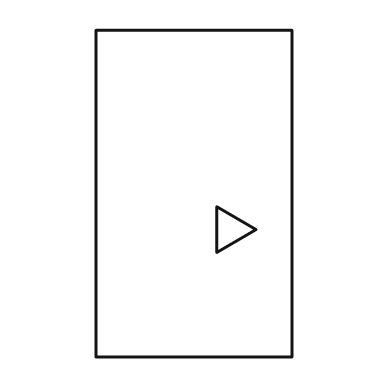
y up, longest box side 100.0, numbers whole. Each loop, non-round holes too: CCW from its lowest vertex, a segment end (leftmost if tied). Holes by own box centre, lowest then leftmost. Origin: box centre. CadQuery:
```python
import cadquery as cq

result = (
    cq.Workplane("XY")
    .moveTo(-30.0, -50.0)
    .lineTo(30.0, -50.0)
    .lineTo(30.0, 50.0)
    .lineTo(-30.0, 50.0)
    .close()
    .moveTo(7.0, -18.0)
    .lineTo(19.0, -11.0)
    .lineTo(7.0, -4.0)
    .close()
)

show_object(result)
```